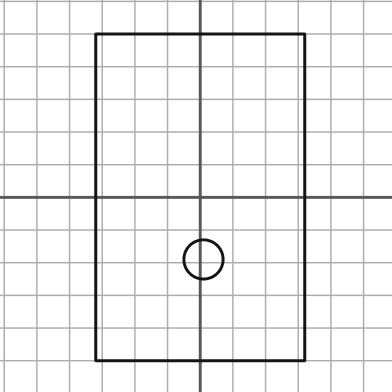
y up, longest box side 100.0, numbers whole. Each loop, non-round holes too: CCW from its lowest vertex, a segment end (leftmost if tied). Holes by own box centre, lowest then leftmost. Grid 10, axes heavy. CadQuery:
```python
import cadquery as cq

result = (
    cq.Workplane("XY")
    .moveTo(-32.0, -50.0)
    .lineTo(32.0, -50.0)
    .lineTo(32.0, 50.0)
    .lineTo(-32.0, 50.0)
    .close()
    .moveTo(1.0, -19.0)
    .circle(6.0)
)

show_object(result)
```